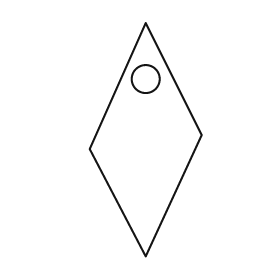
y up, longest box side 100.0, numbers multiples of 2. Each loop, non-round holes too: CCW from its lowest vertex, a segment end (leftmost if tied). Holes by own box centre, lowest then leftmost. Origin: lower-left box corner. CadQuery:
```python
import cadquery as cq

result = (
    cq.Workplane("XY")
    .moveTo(24.0, 0.0)
    .lineTo(48.0, 52.0)
    .lineTo(24.0, 100.0)
    .lineTo(0.0, 46.0)
    .close()
    .moveTo(24.0, 76.0)
    .circle(6.0)
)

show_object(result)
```